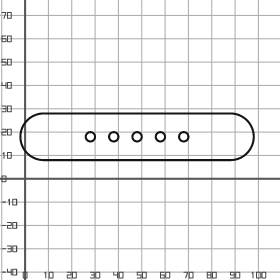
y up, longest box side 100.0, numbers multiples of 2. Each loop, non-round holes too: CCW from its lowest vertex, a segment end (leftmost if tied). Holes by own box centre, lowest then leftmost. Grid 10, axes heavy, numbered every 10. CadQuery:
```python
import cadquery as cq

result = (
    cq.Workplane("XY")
    .moveTo(8.0, 8.0)
    .lineTo(88.0, 8.0)
    .threePointArc((98.0, 18.0), (88.0, 28.0))
    .lineTo(8.0, 28.0)
    .threePointArc((-2.0, 18.0), (8.0, 8.0))
    .close()
    .moveTo(28.0, 18.0)
    .circle(2.0)
    .moveTo(38.0, 18.0)
    .circle(2.0)
    .moveTo(48.0, 18.0)
    .circle(2.0)
    .moveTo(58.0, 18.0)
    .circle(2.0)
    .moveTo(68.0, 18.0)
    .circle(2.0)
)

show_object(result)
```